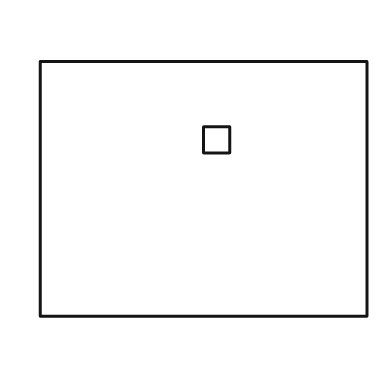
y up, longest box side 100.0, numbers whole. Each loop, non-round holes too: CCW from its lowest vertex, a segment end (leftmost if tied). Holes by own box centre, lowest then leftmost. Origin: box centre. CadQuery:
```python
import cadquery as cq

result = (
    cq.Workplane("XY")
    .moveTo(-50.0, -39.0)
    .lineTo(50.0, -39.0)
    .lineTo(50.0, 39.0)
    .lineTo(-50.0, 39.0)
    .close()
    .moveTo(0.0, 11.0)
    .lineTo(8.0, 11.0)
    .lineTo(8.0, 19.0)
    .lineTo(0.0, 19.0)
    .close()
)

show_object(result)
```